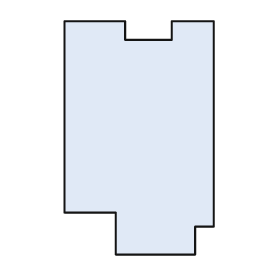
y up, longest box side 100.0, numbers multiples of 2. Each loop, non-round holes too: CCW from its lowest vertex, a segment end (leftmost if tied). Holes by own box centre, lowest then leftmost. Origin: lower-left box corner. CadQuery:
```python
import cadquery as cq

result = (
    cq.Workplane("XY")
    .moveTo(22.0, 0.0)
    .lineTo(56.0, 0.0)
    .lineTo(56.0, 12.0)
    .lineTo(64.0, 12.0)
    .lineTo(64.0, 100.0)
    .lineTo(46.0, 100.0)
    .lineTo(46.0, 92.0)
    .lineTo(26.0, 92.0)
    .lineTo(26.0, 100.0)
    .lineTo(0.0, 100.0)
    .lineTo(0.0, 18.0)
    .lineTo(22.0, 18.0)
    .close()
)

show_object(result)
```